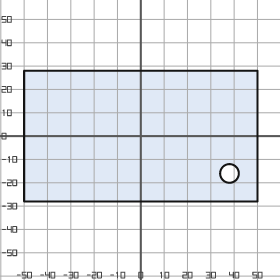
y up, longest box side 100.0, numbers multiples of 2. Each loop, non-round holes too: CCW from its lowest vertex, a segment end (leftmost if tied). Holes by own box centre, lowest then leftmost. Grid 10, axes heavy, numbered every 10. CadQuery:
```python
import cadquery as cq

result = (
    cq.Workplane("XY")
    .moveTo(-50.0, -28.0)
    .lineTo(50.0, -28.0)
    .lineTo(50.0, 28.0)
    .lineTo(-50.0, 28.0)
    .close()
    .moveTo(38.0, -16.0)
    .circle(4.0)
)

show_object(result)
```